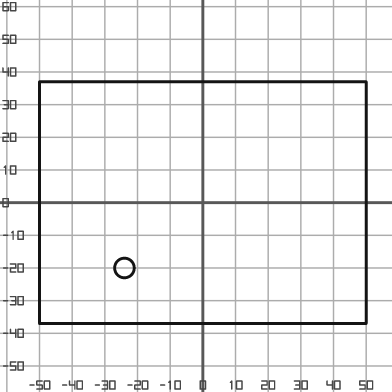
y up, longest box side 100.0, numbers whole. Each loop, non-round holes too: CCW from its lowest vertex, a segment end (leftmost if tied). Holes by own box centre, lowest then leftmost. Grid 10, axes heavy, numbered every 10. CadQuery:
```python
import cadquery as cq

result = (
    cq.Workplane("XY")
    .moveTo(-50.0, -37.0)
    .lineTo(50.0, -37.0)
    .lineTo(50.0, 37.0)
    .lineTo(-50.0, 37.0)
    .close()
    .moveTo(-24.0, -20.0)
    .circle(3.0)
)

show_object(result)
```